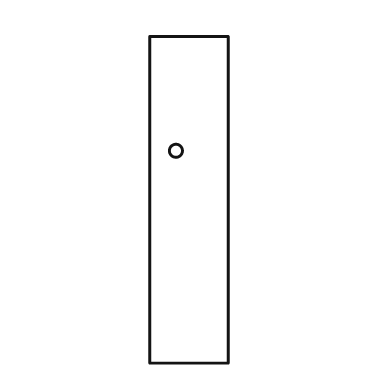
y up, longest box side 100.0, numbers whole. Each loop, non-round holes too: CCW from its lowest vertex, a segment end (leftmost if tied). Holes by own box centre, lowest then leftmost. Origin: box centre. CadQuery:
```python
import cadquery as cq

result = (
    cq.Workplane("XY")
    .moveTo(-12.0, -50.0)
    .lineTo(12.0, -50.0)
    .lineTo(12.0, 50.0)
    .lineTo(-12.0, 50.0)
    .close()
    .moveTo(-4.0, 15.0)
    .circle(2.0)
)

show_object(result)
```